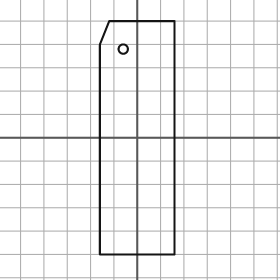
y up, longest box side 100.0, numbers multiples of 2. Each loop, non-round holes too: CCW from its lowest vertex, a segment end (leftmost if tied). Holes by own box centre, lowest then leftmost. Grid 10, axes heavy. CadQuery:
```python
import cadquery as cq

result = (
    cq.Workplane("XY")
    .moveTo(-16.0, -50.0)
    .lineTo(16.0, -50.0)
    .lineTo(16.0, 50.0)
    .lineTo(-12.0, 50.0)
    .lineTo(-16.0, 40.0)
    .close()
    .moveTo(-6.0, 38.0)
    .circle(2.0)
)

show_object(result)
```